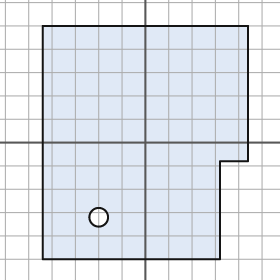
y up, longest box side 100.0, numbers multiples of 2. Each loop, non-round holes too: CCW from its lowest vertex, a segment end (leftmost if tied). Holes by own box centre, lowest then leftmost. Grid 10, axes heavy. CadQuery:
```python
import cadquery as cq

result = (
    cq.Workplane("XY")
    .moveTo(-44.0, -50.0)
    .lineTo(32.0, -50.0)
    .lineTo(32.0, -8.0)
    .lineTo(44.0, -8.0)
    .lineTo(44.0, 50.0)
    .lineTo(-44.0, 50.0)
    .close()
    .moveTo(-20.0, -32.0)
    .circle(4.0)
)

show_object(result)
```